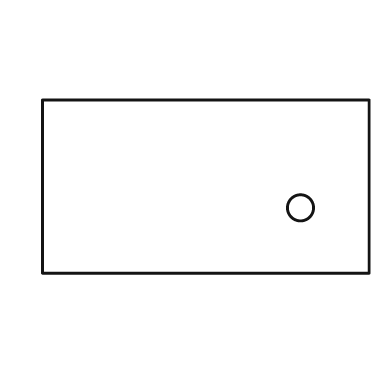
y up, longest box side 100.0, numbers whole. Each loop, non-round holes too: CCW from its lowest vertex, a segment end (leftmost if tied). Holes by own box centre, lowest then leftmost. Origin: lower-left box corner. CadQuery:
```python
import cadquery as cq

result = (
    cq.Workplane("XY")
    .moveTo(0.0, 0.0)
    .lineTo(100.0, 0.0)
    .lineTo(100.0, 53.0)
    .lineTo(0.0, 53.0)
    .close()
    .moveTo(79.0, 20.0)
    .circle(4.0)
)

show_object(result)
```